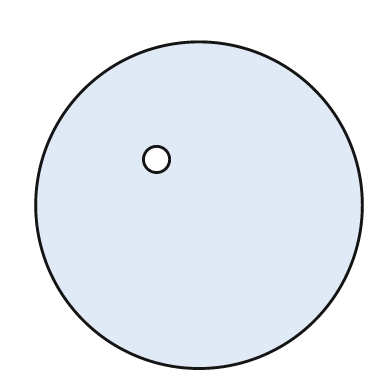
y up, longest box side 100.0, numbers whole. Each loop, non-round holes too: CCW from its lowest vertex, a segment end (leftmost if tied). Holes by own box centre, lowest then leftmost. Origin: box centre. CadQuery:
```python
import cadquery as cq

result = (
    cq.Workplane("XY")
    .moveTo(0.0, 0.0)
    .circle(50.0)
    .moveTo(-13.0, 14.0)
    .circle(4.0)
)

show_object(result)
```